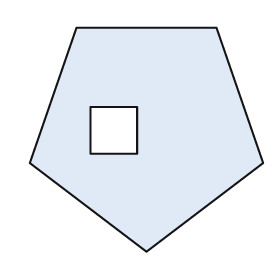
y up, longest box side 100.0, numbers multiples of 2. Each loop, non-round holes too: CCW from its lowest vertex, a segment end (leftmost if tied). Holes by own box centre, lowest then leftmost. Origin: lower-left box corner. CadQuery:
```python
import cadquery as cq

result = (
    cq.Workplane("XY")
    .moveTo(50.0, 0.0)
    .lineTo(100.0, 38.0)
    .lineTo(80.0, 96.0)
    .lineTo(20.0, 96.0)
    .lineTo(0.0, 38.0)
    .close()
    .moveTo(26.0, 42.0)
    .lineTo(46.0, 42.0)
    .lineTo(46.0, 62.0)
    .lineTo(26.0, 62.0)
    .close()
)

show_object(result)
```